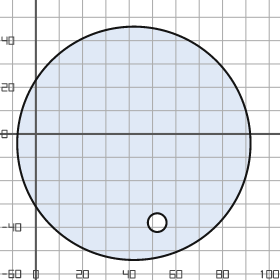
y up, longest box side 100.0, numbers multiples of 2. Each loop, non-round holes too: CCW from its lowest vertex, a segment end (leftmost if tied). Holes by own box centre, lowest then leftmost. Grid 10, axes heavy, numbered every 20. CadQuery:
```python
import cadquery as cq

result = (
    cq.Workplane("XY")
    .moveTo(42.0, -4.0)
    .circle(50.0)
    .moveTo(52.0, -38.0)
    .circle(4.0)
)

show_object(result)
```